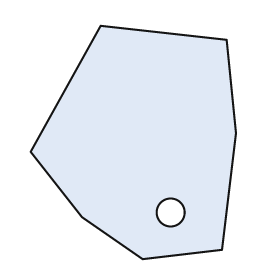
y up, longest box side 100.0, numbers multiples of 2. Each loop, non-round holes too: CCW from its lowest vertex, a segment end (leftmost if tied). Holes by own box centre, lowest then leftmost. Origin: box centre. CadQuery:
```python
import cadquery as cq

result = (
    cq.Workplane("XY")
    .moveTo(4.0, -50.0)
    .lineTo(38.0, -46.0)
    .lineTo(44.0, 4.0)
    .lineTo(40.0, 44.0)
    .lineTo(-14.0, 50.0)
    .lineTo(-44.0, -4.0)
    .lineTo(-22.0, -32.0)
    .close()
    .moveTo(16.0, -30.0)
    .circle(6.0)
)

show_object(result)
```